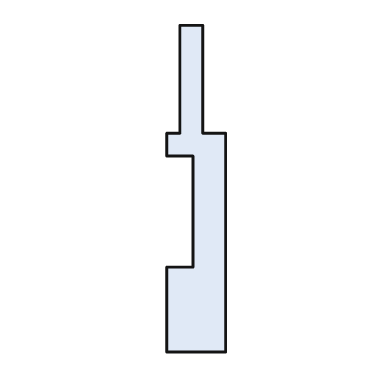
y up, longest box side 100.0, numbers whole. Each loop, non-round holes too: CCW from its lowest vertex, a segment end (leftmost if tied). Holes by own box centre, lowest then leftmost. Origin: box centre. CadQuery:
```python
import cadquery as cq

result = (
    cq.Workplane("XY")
    .moveTo(-9.0, -50.0)
    .lineTo(9.0, -50.0)
    .lineTo(9.0, 17.0)
    .lineTo(2.0, 17.0)
    .lineTo(2.0, 50.0)
    .lineTo(-5.0, 50.0)
    .lineTo(-5.0, 17.0)
    .lineTo(-9.0, 17.0)
    .lineTo(-9.0, 10.0)
    .lineTo(-1.0, 10.0)
    .lineTo(-1.0, -24.0)
    .lineTo(-9.0, -24.0)
    .close()
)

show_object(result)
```